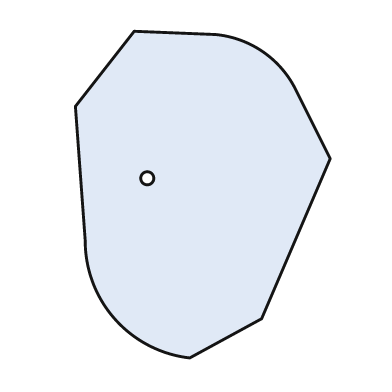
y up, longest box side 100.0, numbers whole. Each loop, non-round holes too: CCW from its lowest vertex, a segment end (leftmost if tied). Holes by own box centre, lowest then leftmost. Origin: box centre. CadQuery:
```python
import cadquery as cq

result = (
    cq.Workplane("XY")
    .moveTo(-4.0, -50.0)
    .lineTo(18.0, -38.0)
    .lineTo(39.0, 11.0)
    .lineTo(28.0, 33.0)
    .threePointArc((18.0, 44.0), (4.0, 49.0))
    .lineTo(-21.0, 50.0)
    .lineTo(-39.0, 27.0)
    .lineTo(-36.0, -14.0)
    .threePointArc((-27.0, -38.0), (-4.0, -50.0))
    .close()
    .moveTo(-17.0, 5.0)
    .circle(2.0)
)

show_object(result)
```